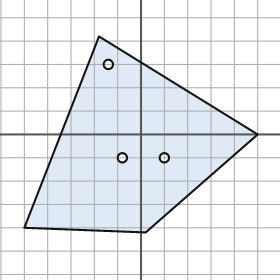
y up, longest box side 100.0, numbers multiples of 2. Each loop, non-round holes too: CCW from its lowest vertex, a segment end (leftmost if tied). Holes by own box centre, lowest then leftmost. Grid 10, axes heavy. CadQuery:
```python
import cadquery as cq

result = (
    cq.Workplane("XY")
    .moveTo(2.0, -42.0)
    .lineTo(50.0, 0.0)
    .lineTo(-18.0, 42.0)
    .lineTo(-50.0, -40.0)
    .close()
    .moveTo(-8.0, -10.0)
    .circle(2.0)
    .moveTo(10.0, -10.0)
    .circle(2.0)
    .moveTo(-14.0, 30.0)
    .circle(2.0)
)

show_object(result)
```